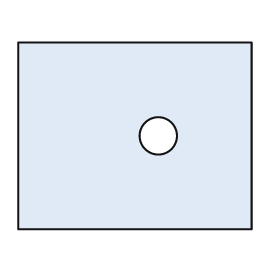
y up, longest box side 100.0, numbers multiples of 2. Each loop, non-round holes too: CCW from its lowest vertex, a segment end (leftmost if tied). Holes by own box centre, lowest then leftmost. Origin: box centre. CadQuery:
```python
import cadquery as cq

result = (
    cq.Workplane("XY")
    .moveTo(-50.0, -40.0)
    .lineTo(50.0, -40.0)
    .lineTo(50.0, 40.0)
    .lineTo(-50.0, 40.0)
    .close()
    .moveTo(10.0, 0.0)
    .circle(8.0)
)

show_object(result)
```